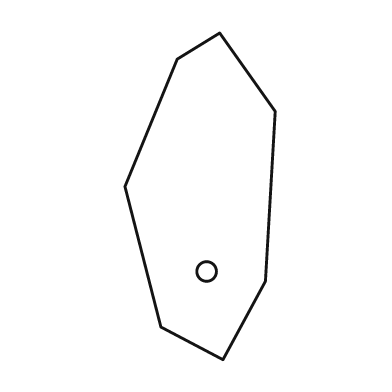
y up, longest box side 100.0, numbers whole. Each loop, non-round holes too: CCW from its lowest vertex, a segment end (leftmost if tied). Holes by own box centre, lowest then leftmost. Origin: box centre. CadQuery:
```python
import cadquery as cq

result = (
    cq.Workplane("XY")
    .moveTo(7.0, -50.0)
    .lineTo(20.0, -26.0)
    .lineTo(23.0, 26.0)
    .lineTo(6.0, 50.0)
    .lineTo(-7.0, 42.0)
    .lineTo(-23.0, 3.0)
    .lineTo(-12.0, -40.0)
    .close()
    .moveTo(2.0, -23.0)
    .circle(3.0)
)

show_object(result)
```